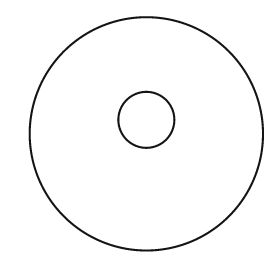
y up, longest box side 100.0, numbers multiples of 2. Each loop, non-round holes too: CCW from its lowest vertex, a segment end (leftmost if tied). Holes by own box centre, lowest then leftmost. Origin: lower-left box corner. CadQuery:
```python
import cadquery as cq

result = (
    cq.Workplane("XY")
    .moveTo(50.0, 50.0)
    .circle(50.0)
    .moveTo(50.0, 56.0)
    .circle(12.0)
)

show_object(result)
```